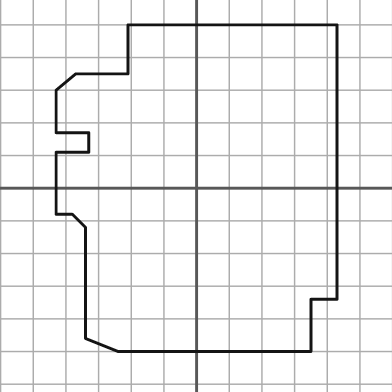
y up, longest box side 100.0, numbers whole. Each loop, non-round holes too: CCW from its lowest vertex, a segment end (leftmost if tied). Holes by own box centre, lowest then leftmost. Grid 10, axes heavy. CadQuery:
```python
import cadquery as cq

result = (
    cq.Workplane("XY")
    .moveTo(-24.0, -50.0)
    .lineTo(35.0, -50.0)
    .lineTo(35.0, -34.0)
    .lineTo(43.0, -34.0)
    .lineTo(43.0, 50.0)
    .lineTo(-21.0, 50.0)
    .lineTo(-21.0, 35.0)
    .lineTo(-37.0, 35.0)
    .lineTo(-43.0, 30.0)
    .lineTo(-43.0, 17.0)
    .lineTo(-33.0, 17.0)
    .lineTo(-33.0, 11.0)
    .lineTo(-43.0, 11.0)
    .lineTo(-43.0, -8.0)
    .lineTo(-38.0, -8.0)
    .lineTo(-34.0, -12.0)
    .lineTo(-34.0, -46.0)
    .close()
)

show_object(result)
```